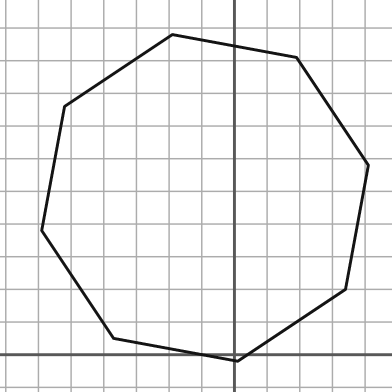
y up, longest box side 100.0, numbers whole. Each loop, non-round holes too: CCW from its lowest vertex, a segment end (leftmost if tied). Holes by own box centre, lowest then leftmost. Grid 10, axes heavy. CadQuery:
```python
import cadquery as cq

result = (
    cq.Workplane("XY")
    .moveTo(1.0, -2.0)
    .lineTo(34.0, 20.0)
    .lineTo(41.0, 58.0)
    .lineTo(19.0, 91.0)
    .lineTo(-19.0, 98.0)
    .lineTo(-52.0, 76.0)
    .lineTo(-59.0, 38.0)
    .lineTo(-37.0, 5.0)
    .close()
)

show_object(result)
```